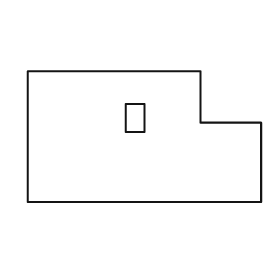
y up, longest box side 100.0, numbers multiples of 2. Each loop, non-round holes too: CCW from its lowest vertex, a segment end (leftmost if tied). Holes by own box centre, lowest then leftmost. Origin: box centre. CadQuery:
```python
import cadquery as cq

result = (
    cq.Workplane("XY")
    .moveTo(-50.0, -28.0)
    .lineTo(50.0, -28.0)
    .lineTo(50.0, 6.0)
    .lineTo(24.0, 6.0)
    .lineTo(24.0, 28.0)
    .lineTo(-50.0, 28.0)
    .close()
    .moveTo(-8.0, 2.0)
    .lineTo(0.0, 2.0)
    .lineTo(0.0, 14.0)
    .lineTo(-8.0, 14.0)
    .close()
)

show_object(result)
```